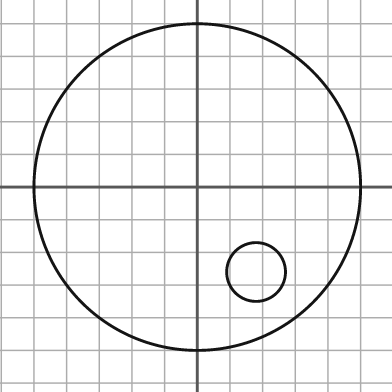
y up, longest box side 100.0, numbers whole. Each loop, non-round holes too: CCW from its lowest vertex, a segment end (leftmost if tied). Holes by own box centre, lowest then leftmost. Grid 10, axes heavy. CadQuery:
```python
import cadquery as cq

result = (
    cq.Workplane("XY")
    .moveTo(0.0, 0.0)
    .circle(50.0)
    .moveTo(18.0, -26.0)
    .circle(9.0)
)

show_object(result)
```